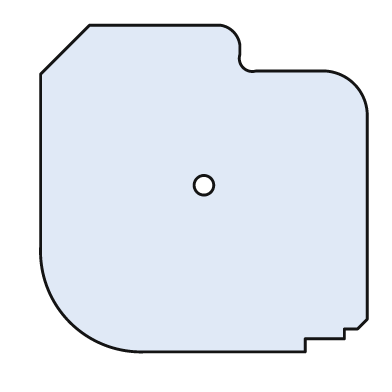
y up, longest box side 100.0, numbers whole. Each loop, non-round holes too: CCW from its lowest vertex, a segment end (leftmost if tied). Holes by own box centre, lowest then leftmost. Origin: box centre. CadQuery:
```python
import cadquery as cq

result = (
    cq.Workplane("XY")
    .moveTo(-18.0, -50.0)
    .lineTo(31.0, -50.0)
    .lineTo(31.0, -46.0)
    .lineTo(43.0, -46.0)
    .lineTo(43.0, -43.0)
    .lineTo(47.0, -43.0)
    .lineTo(50.0, -40.0)
    .lineTo(50.0, 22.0)
    .threePointArc((46.0, 32.0), (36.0, 36.0))
    .lineTo(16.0, 36.0)
    .threePointArc((12.0, 37.0), (11.0, 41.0))
    .lineTo(11.0, 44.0)
    .threePointArc((9.0, 48.0), (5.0, 50.0))
    .lineTo(-35.0, 50.0)
    .lineTo(-50.0, 35.0)
    .lineTo(-50.0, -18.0)
    .threePointArc((-41.0, -41.0), (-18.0, -50.0))
    .close()
    .moveTo(0.0, 1.0)
    .circle(3.0)
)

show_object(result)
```